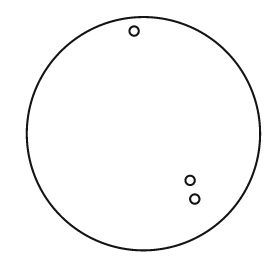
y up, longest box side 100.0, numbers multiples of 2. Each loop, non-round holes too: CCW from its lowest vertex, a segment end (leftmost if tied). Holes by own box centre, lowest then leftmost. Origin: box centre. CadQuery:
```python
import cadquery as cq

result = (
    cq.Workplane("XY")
    .moveTo(0.0, 0.0)
    .circle(50.0)
    .moveTo(22.0, -28.0)
    .circle(2.0)
    .moveTo(20.0, -20.0)
    .circle(2.0)
    .moveTo(-4.0, 44.0)
    .circle(2.0)
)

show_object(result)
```